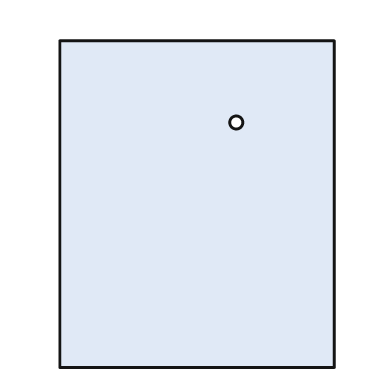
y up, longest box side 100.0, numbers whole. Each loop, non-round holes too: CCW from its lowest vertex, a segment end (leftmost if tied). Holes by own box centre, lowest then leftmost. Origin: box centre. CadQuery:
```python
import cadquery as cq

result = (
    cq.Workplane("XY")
    .moveTo(-42.0, -50.0)
    .lineTo(42.0, -50.0)
    .lineTo(42.0, 50.0)
    .lineTo(-42.0, 50.0)
    .close()
    .moveTo(12.0, 25.0)
    .circle(2.0)
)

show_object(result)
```